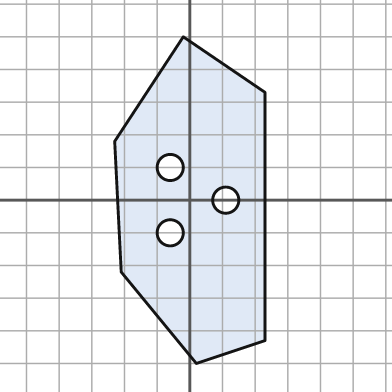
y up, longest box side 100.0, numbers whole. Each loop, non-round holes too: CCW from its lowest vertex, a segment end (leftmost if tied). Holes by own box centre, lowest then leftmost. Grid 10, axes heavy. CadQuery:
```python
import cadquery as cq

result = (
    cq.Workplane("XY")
    .moveTo(2.0, -50.0)
    .lineTo(23.0, -43.0)
    .lineTo(23.0, 33.0)
    .lineTo(-2.0, 50.0)
    .lineTo(-23.0, 18.0)
    .lineTo(-21.0, -22.0)
    .close()
    .moveTo(-6.0, -10.0)
    .circle(4.0)
    .moveTo(11.0, 0.0)
    .circle(4.0)
    .moveTo(-6.0, 10.0)
    .circle(4.0)
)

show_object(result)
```